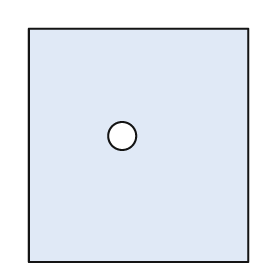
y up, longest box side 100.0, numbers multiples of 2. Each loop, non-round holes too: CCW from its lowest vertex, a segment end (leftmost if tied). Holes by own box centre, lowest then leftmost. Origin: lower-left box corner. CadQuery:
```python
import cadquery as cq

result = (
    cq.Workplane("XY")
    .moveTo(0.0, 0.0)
    .lineTo(94.0, 0.0)
    .lineTo(94.0, 100.0)
    .lineTo(0.0, 100.0)
    .close()
    .moveTo(40.0, 54.0)
    .circle(6.0)
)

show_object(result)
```